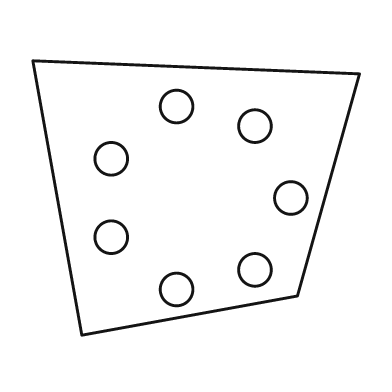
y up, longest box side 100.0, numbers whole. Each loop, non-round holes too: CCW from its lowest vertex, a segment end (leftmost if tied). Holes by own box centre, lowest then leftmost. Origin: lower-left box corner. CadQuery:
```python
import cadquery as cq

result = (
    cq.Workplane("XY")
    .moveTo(15.0, 0.0)
    .lineTo(81.0, 12.0)
    .lineTo(100.0, 80.0)
    .lineTo(0.0, 84.0)
    .close()
    .moveTo(44.0, 14.0)
    .circle(5.0)
    .moveTo(68.0, 20.0)
    .circle(5.0)
    .moveTo(24.0, 30.0)
    .circle(5.0)
    .moveTo(79.0, 42.0)
    .circle(5.0)
    .moveTo(24.0, 54.0)
    .circle(5.0)
    .moveTo(68.0, 64.0)
    .circle(5.0)
    .moveTo(44.0, 70.0)
    .circle(5.0)
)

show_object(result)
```